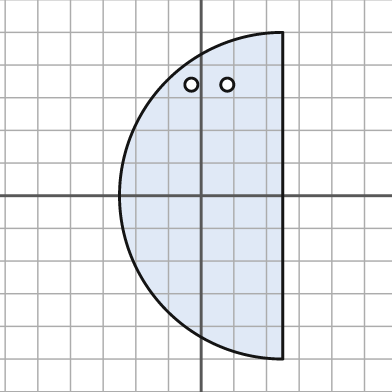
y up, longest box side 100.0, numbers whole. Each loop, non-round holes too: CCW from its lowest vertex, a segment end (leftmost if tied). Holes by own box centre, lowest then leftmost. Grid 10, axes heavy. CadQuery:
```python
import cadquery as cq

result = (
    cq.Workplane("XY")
    .moveTo(25.0, -50.0)
    .lineTo(25.0, 50.0)
    .threePointArc((-25.0, 0.0), (25.0, -50.0))
    .close()
    .moveTo(-3.0, 34.0)
    .circle(2.0)
    .moveTo(8.0, 34.0)
    .circle(2.0)
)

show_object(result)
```